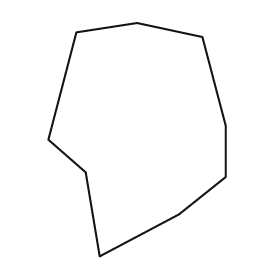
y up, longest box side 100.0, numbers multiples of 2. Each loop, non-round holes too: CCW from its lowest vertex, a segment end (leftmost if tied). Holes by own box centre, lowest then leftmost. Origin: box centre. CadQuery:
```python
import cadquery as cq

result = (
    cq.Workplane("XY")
    .moveTo(-16.0, -50.0)
    .lineTo(18.0, -32.0)
    .lineTo(38.0, -16.0)
    .lineTo(38.0, 6.0)
    .lineTo(28.0, 44.0)
    .lineTo(0.0, 50.0)
    .lineTo(-26.0, 46.0)
    .lineTo(-38.0, 0.0)
    .lineTo(-22.0, -14.0)
    .close()
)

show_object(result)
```